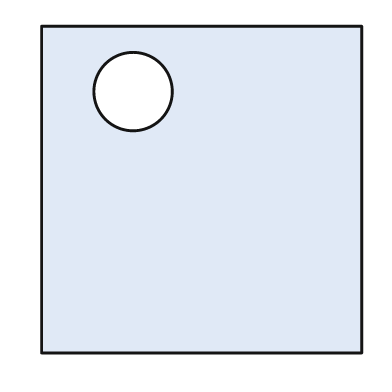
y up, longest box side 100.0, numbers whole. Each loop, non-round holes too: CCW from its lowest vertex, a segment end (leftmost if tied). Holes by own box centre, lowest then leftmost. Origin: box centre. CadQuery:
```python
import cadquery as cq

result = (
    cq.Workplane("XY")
    .moveTo(-49.0, -50.0)
    .lineTo(49.0, -50.0)
    .lineTo(49.0, 50.0)
    .lineTo(-49.0, 50.0)
    .close()
    .moveTo(-21.0, 30.0)
    .circle(12.0)
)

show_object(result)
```